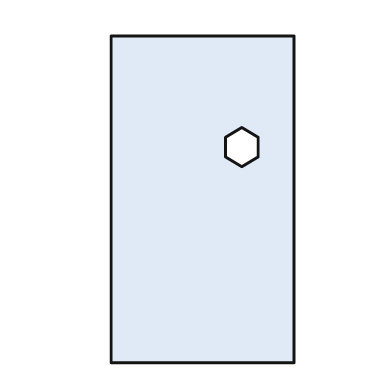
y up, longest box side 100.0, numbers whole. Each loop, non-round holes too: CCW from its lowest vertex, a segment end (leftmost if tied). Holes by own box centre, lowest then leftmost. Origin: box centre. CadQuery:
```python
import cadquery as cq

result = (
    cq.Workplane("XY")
    .moveTo(-28.0, -50.0)
    .lineTo(28.0, -50.0)
    .lineTo(28.0, 50.0)
    .lineTo(-28.0, 50.0)
    .close()
    .moveTo(12.0, 10.0)
    .lineTo(17.0, 13.0)
    .lineTo(17.0, 19.0)
    .lineTo(12.0, 22.0)
    .lineTo(7.0, 19.0)
    .lineTo(7.0, 13.0)
    .close()
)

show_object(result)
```